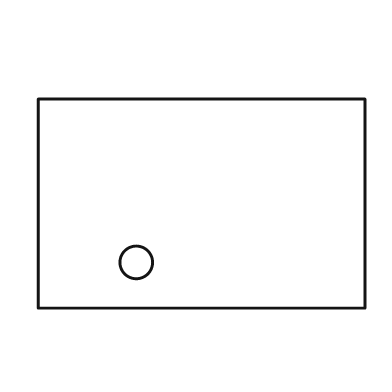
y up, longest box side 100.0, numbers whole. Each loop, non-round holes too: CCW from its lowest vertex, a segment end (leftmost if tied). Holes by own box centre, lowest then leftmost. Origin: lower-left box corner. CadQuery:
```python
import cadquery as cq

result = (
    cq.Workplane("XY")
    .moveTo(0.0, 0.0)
    .lineTo(100.0, 0.0)
    .lineTo(100.0, 64.0)
    .lineTo(0.0, 64.0)
    .close()
    .moveTo(30.0, 14.0)
    .circle(5.0)
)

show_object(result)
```